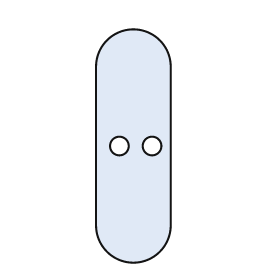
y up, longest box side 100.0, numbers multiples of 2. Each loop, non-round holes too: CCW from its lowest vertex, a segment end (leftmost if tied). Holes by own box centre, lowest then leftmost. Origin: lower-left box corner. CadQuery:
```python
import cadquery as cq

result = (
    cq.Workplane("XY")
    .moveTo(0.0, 16.0)
    .threePointArc((16.0, 0.0), (32.0, 16.0))
    .lineTo(32.0, 84.0)
    .threePointArc((16.0, 100.0), (0.0, 84.0))
    .close()
    .moveTo(10.0, 50.0)
    .circle(4.0)
    .moveTo(24.0, 50.0)
    .circle(4.0)
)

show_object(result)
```